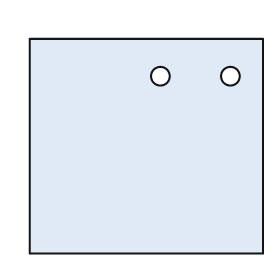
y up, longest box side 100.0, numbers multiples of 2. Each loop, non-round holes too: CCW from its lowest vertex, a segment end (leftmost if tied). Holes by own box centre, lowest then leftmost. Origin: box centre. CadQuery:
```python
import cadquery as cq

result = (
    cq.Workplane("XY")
    .moveTo(-50.0, -46.0)
    .lineTo(50.0, -46.0)
    .lineTo(50.0, 46.0)
    .lineTo(-50.0, 46.0)
    .close()
    .moveTo(6.0, 30.0)
    .circle(4.0)
    .moveTo(36.0, 30.0)
    .circle(4.0)
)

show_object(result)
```